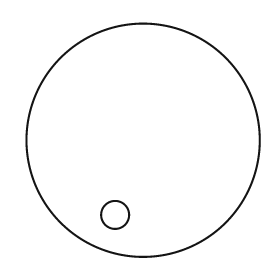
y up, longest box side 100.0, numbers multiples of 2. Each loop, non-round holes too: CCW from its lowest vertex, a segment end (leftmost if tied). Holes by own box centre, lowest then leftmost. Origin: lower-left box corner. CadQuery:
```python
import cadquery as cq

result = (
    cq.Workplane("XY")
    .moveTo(50.0, 50.0)
    .circle(50.0)
    .moveTo(38.0, 18.0)
    .circle(6.0)
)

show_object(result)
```